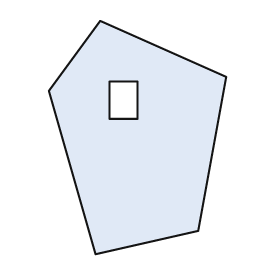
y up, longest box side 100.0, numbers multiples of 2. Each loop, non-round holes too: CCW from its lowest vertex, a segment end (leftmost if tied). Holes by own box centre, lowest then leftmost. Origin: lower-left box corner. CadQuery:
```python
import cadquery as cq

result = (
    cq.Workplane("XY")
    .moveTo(20.0, 0.0)
    .lineTo(64.0, 10.0)
    .lineTo(76.0, 76.0)
    .lineTo(22.0, 100.0)
    .lineTo(0.0, 70.0)
    .close()
    .moveTo(26.0, 58.0)
    .lineTo(38.0, 58.0)
    .lineTo(38.0, 74.0)
    .lineTo(26.0, 74.0)
    .close()
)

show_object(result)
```